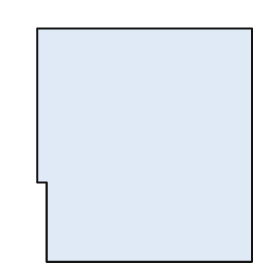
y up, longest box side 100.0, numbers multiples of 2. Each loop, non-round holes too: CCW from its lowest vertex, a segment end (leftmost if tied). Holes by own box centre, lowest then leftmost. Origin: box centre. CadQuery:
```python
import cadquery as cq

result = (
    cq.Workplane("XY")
    .moveTo(-42.0, -50.0)
    .lineTo(46.0, -50.0)
    .lineTo(46.0, 50.0)
    .lineTo(-46.0, 50.0)
    .lineTo(-46.0, -16.0)
    .lineTo(-42.0, -16.0)
    .close()
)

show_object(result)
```